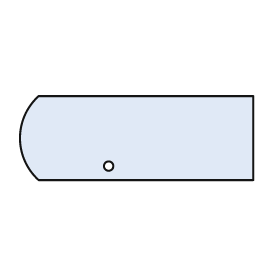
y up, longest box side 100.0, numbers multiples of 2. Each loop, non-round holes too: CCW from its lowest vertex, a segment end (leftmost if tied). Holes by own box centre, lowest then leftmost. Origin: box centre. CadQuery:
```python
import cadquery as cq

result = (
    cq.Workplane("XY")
    .moveTo(-42.0, -18.0)
    .lineTo(50.0, -18.0)
    .lineTo(50.0, 18.0)
    .lineTo(-42.0, 18.0)
    .threePointArc((-50.0, 0.0), (-42.0, -18.0))
    .close()
    .moveTo(-12.0, -12.0)
    .circle(2.0)
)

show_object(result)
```